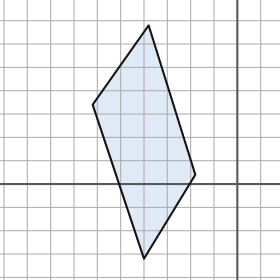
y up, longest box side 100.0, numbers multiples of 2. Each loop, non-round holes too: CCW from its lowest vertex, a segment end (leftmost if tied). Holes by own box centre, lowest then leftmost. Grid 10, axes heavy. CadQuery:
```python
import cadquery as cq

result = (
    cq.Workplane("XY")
    .moveTo(-40.0, -32.0)
    .lineTo(-18.0, 4.0)
    .lineTo(-38.0, 68.0)
    .lineTo(-62.0, 34.0)
    .close()
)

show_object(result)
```